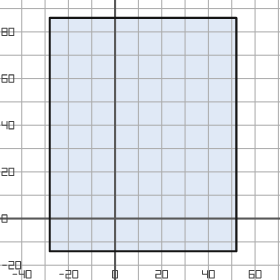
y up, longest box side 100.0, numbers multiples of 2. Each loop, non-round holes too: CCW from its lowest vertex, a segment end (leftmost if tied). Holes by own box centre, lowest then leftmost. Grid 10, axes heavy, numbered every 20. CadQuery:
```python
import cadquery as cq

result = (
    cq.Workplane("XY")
    .moveTo(-28.0, -14.0)
    .lineTo(52.0, -14.0)
    .lineTo(52.0, 86.0)
    .lineTo(-28.0, 86.0)
    .close()
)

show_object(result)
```